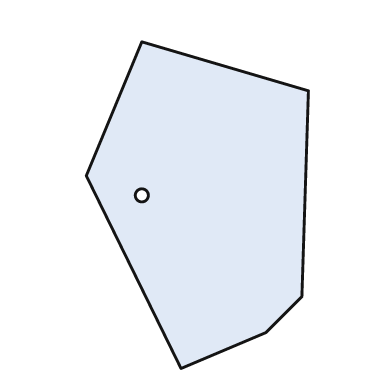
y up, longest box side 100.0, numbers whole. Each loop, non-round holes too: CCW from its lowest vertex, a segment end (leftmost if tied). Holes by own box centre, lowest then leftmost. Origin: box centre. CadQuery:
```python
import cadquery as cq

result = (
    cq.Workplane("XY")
    .moveTo(-5.0, -50.0)
    .lineTo(21.0, -39.0)
    .lineTo(32.0, -28.0)
    .lineTo(34.0, 35.0)
    .lineTo(-17.0, 50.0)
    .lineTo(-34.0, 9.0)
    .close()
    .moveTo(-17.0, 3.0)
    .circle(2.0)
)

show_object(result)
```